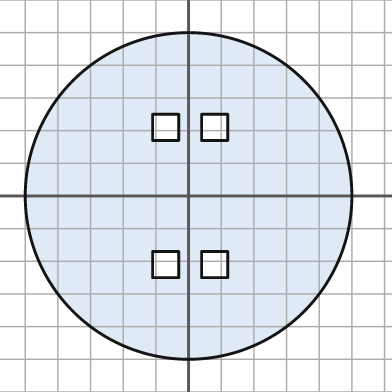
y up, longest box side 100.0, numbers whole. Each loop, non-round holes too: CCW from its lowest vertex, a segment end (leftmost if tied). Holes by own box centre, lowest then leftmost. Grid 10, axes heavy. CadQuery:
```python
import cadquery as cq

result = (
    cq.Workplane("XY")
    .moveTo(0.0, 0.0)
    .circle(50.0)
    .moveTo(-11.0, -25.0)
    .lineTo(-3.0, -25.0)
    .lineTo(-3.0, -17.0)
    .lineTo(-11.0, -17.0)
    .close()
    .moveTo(4.0, -25.0)
    .lineTo(12.0, -25.0)
    .lineTo(12.0, -17.0)
    .lineTo(4.0, -17.0)
    .close()
    .moveTo(-11.0, 17.0)
    .lineTo(-3.0, 17.0)
    .lineTo(-3.0, 25.0)
    .lineTo(-11.0, 25.0)
    .close()
    .moveTo(4.0, 17.0)
    .lineTo(12.0, 17.0)
    .lineTo(12.0, 25.0)
    .lineTo(4.0, 25.0)
    .close()
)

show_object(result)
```